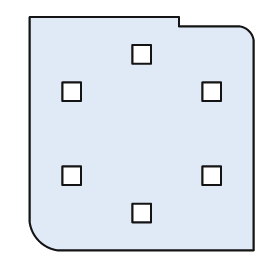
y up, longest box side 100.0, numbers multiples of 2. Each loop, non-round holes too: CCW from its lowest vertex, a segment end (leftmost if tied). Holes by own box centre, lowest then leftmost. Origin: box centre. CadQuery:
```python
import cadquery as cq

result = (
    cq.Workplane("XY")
    .moveTo(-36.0, -50.0)
    .lineTo(48.0, -50.0)
    .lineTo(48.0, 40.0)
    .threePointArc((46.0, 44.0), (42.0, 46.0))
    .lineTo(16.0, 46.0)
    .lineTo(16.0, 50.0)
    .lineTo(-48.0, 50.0)
    .lineTo(-48.0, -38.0)
    .threePointArc((-44.0, -46.0), (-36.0, -50.0))
    .close()
    .moveTo(-4.0, -38.0)
    .lineTo(4.0, -38.0)
    .lineTo(4.0, -30.0)
    .lineTo(-4.0, -30.0)
    .close()
    .moveTo(-34.0, -22.0)
    .lineTo(-26.0, -22.0)
    .lineTo(-26.0, -14.0)
    .lineTo(-34.0, -14.0)
    .close()
    .moveTo(26.0, -22.0)
    .lineTo(34.0, -22.0)
    .lineTo(34.0, -14.0)
    .lineTo(26.0, -14.0)
    .close()
    .moveTo(-34.0, 14.0)
    .lineTo(-26.0, 14.0)
    .lineTo(-26.0, 22.0)
    .lineTo(-34.0, 22.0)
    .close()
    .moveTo(26.0, 14.0)
    .lineTo(34.0, 14.0)
    .lineTo(34.0, 22.0)
    .lineTo(26.0, 22.0)
    .close()
    .moveTo(-4.0, 30.0)
    .lineTo(4.0, 30.0)
    .lineTo(4.0, 38.0)
    .lineTo(-4.0, 38.0)
    .close()
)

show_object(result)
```